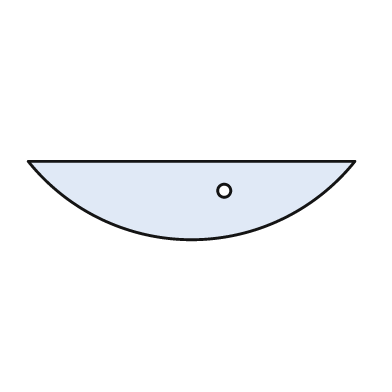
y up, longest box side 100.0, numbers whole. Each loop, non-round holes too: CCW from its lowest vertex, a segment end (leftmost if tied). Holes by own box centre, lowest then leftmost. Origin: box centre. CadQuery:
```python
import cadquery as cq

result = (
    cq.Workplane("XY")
    .moveTo(-50.0, 12.0)
    .threePointArc((0.0, -12.0), (50.0, 12.0))
    .close()
    .moveTo(10.0, 3.0)
    .circle(2.0)
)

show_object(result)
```